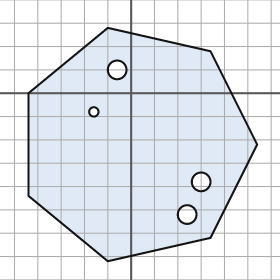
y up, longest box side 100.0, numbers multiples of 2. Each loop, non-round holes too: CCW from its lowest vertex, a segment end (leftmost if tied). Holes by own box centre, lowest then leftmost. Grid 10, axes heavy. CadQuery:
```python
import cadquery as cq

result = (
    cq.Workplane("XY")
    .moveTo(-10.0, -72.0)
    .lineTo(34.0, -62.0)
    .lineTo(54.0, -22.0)
    .lineTo(34.0, 18.0)
    .lineTo(-10.0, 28.0)
    .lineTo(-44.0, 0.0)
    .lineTo(-44.0, -44.0)
    .close()
    .moveTo(24.0, -52.0)
    .circle(4.0)
    .moveTo(30.0, -38.0)
    .circle(4.0)
    .moveTo(-16.0, -8.0)
    .circle(2.0)
    .moveTo(-6.0, 10.0)
    .circle(4.0)
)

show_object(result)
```